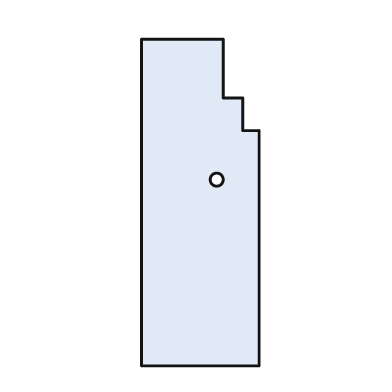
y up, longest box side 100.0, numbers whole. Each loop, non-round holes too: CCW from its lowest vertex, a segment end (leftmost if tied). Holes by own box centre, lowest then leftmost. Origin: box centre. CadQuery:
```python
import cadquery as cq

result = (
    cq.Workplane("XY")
    .moveTo(-18.0, -50.0)
    .lineTo(18.0, -50.0)
    .lineTo(18.0, 22.0)
    .lineTo(13.0, 22.0)
    .lineTo(13.0, 32.0)
    .lineTo(7.0, 32.0)
    .lineTo(7.0, 50.0)
    .lineTo(-18.0, 50.0)
    .close()
    .moveTo(5.0, 7.0)
    .circle(2.0)
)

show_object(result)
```